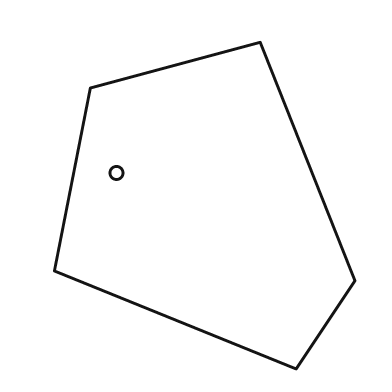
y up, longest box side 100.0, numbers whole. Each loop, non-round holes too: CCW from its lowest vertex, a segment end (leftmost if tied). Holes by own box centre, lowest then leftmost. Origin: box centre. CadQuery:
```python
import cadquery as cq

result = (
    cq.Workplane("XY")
    .moveTo(28.0, -50.0)
    .lineTo(46.0, -23.0)
    .lineTo(17.0, 50.0)
    .lineTo(-35.0, 36.0)
    .lineTo(-46.0, -20.0)
    .close()
    .moveTo(-27.0, 10.0)
    .circle(2.0)
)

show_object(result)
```